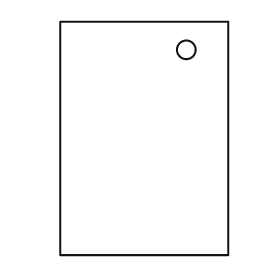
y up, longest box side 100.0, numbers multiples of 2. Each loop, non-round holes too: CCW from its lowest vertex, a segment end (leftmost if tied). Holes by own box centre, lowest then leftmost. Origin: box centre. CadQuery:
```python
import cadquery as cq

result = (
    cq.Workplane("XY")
    .moveTo(-36.0, -50.0)
    .lineTo(36.0, -50.0)
    .lineTo(36.0, 50.0)
    .lineTo(-36.0, 50.0)
    .close()
    .moveTo(18.0, 38.0)
    .circle(4.0)
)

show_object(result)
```